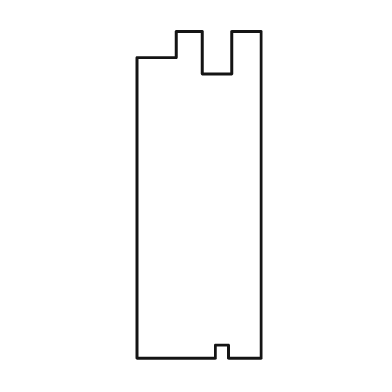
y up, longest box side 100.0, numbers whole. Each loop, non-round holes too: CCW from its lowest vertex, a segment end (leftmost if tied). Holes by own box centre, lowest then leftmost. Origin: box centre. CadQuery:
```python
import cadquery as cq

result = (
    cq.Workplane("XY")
    .moveTo(-19.0, -50.0)
    .lineTo(5.0, -50.0)
    .lineTo(5.0, -46.0)
    .lineTo(9.0, -46.0)
    .lineTo(9.0, -50.0)
    .lineTo(19.0, -50.0)
    .lineTo(19.0, 50.0)
    .lineTo(10.0, 50.0)
    .lineTo(10.0, 37.0)
    .lineTo(1.0, 37.0)
    .lineTo(1.0, 50.0)
    .lineTo(-7.0, 50.0)
    .lineTo(-7.0, 42.0)
    .lineTo(-19.0, 42.0)
    .close()
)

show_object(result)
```